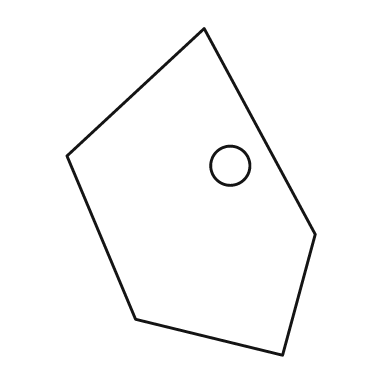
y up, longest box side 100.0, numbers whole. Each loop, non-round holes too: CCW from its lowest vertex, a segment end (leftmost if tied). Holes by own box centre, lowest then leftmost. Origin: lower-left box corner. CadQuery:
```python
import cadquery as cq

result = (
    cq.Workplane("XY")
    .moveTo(66.0, 0.0)
    .lineTo(76.0, 37.0)
    .lineTo(42.0, 100.0)
    .lineTo(0.0, 61.0)
    .lineTo(21.0, 11.0)
    .close()
    .moveTo(50.0, 58.0)
    .circle(6.0)
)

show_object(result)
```